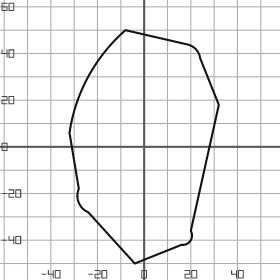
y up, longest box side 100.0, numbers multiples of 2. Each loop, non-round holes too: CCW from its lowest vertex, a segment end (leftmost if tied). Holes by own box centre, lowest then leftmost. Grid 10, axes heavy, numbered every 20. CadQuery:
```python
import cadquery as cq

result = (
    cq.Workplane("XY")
    .moveTo(-4.0, -50.0)
    .lineTo(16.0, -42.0)
    .threePointArc((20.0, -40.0), (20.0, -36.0))
    .lineTo(32.0, 18.0)
    .lineTo(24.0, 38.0)
    .threePointArc((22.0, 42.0), (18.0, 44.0))
    .lineTo(-8.0, 50.0)
    .threePointArc((-24.0, 30.0), (-32.0, 6.0))
    .lineTo(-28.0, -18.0)
    .threePointArc((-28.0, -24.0), (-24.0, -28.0))
    .close()
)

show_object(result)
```